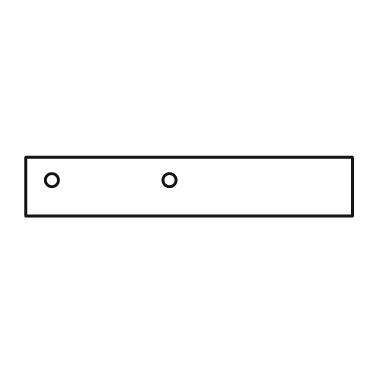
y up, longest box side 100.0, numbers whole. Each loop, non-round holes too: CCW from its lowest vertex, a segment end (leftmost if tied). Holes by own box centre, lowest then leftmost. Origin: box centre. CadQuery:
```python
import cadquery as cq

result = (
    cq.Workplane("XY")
    .moveTo(-50.0, -9.0)
    .lineTo(50.0, -9.0)
    .lineTo(50.0, 9.0)
    .lineTo(-50.0, 9.0)
    .close()
    .moveTo(-42.0, 2.0)
    .circle(2.0)
    .moveTo(-6.0, 2.0)
    .circle(2.0)
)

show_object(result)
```